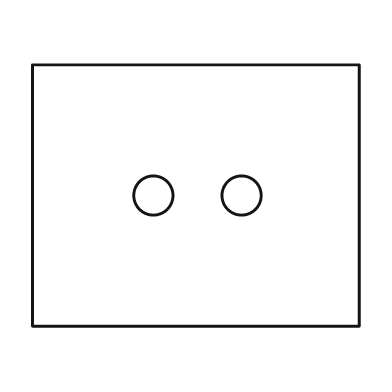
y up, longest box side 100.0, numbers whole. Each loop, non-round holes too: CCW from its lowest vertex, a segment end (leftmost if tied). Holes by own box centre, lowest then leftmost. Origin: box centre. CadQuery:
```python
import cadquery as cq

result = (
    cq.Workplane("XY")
    .moveTo(-50.0, -40.0)
    .lineTo(50.0, -40.0)
    .lineTo(50.0, 40.0)
    .lineTo(-50.0, 40.0)
    .close()
    .moveTo(-13.0, 0.0)
    .circle(6.0)
    .moveTo(14.0, 0.0)
    .circle(6.0)
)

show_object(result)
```